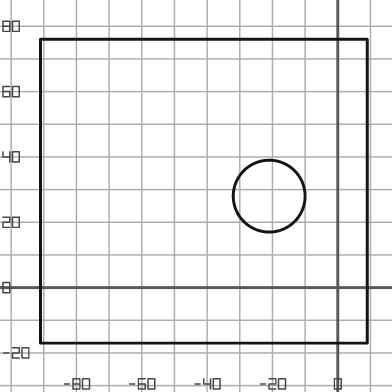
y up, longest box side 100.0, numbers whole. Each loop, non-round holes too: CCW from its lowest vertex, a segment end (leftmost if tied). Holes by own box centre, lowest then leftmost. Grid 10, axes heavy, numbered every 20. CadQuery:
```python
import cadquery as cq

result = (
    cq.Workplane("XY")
    .moveTo(-91.0, -17.0)
    .lineTo(9.0, -17.0)
    .lineTo(9.0, 76.0)
    .lineTo(-91.0, 76.0)
    .close()
    .moveTo(-21.0, 28.0)
    .circle(11.0)
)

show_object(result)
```